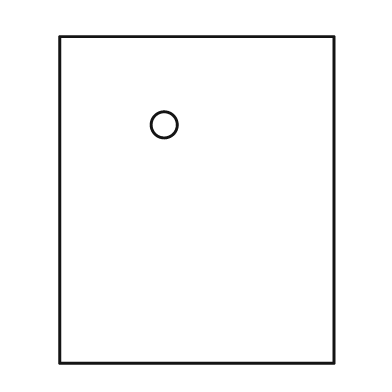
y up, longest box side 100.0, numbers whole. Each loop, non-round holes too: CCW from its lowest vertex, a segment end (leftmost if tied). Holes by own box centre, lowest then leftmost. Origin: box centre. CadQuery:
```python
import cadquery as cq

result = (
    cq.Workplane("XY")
    .moveTo(-42.0, -50.0)
    .lineTo(42.0, -50.0)
    .lineTo(42.0, 50.0)
    .lineTo(-42.0, 50.0)
    .close()
    .moveTo(-10.0, 23.0)
    .circle(4.0)
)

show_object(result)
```